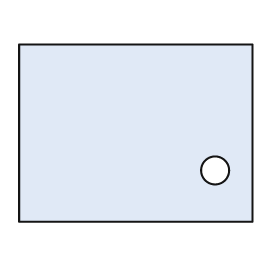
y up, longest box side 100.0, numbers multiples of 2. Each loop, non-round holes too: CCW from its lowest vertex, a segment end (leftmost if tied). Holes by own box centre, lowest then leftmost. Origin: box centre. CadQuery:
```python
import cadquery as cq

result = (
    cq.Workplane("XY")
    .moveTo(-50.0, -38.0)
    .lineTo(50.0, -38.0)
    .lineTo(50.0, 38.0)
    .lineTo(-50.0, 38.0)
    .close()
    .moveTo(34.0, -16.0)
    .circle(6.0)
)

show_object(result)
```